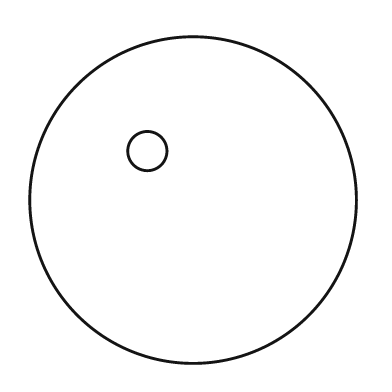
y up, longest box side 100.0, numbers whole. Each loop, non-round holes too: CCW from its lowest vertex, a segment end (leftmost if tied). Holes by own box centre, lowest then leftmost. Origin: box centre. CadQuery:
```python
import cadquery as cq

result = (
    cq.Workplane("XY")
    .moveTo(0.0, 0.0)
    .circle(50.0)
    .moveTo(-14.0, 15.0)
    .circle(6.0)
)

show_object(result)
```